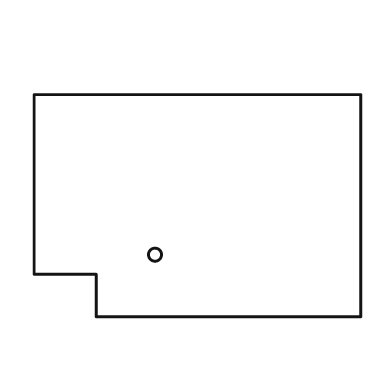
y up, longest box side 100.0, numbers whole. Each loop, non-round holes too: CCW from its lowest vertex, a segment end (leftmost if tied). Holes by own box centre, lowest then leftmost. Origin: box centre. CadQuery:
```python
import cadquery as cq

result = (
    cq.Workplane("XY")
    .moveTo(-31.0, -34.0)
    .lineTo(50.0, -34.0)
    .lineTo(50.0, 34.0)
    .lineTo(-50.0, 34.0)
    .lineTo(-50.0, -21.0)
    .lineTo(-31.0, -21.0)
    .close()
    .moveTo(-13.0, -15.0)
    .circle(2.0)
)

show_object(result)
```